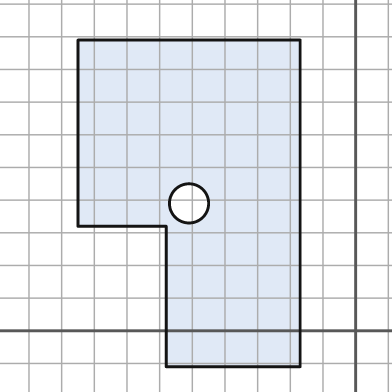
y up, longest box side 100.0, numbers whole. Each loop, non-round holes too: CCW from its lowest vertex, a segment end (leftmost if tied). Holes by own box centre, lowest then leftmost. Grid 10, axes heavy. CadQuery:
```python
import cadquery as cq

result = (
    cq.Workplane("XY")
    .moveTo(-58.0, -11.0)
    .lineTo(-17.0, -11.0)
    .lineTo(-17.0, 89.0)
    .lineTo(-85.0, 89.0)
    .lineTo(-85.0, 32.0)
    .lineTo(-58.0, 32.0)
    .close()
    .moveTo(-51.0, 39.0)
    .circle(6.0)
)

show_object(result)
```